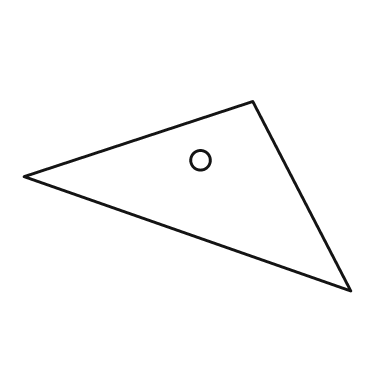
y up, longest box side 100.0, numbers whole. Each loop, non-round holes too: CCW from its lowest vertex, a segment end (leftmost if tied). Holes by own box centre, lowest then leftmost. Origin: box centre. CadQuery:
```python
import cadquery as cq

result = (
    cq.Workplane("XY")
    .moveTo(50.0, -29.0)
    .lineTo(20.0, 29.0)
    .lineTo(-50.0, 6.0)
    .close()
    .moveTo(4.0, 11.0)
    .circle(3.0)
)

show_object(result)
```